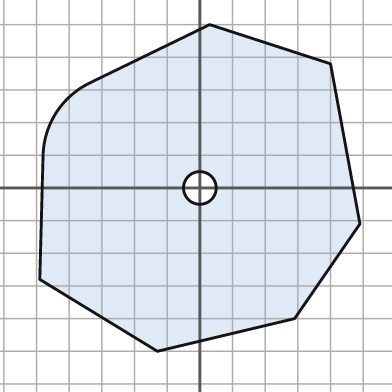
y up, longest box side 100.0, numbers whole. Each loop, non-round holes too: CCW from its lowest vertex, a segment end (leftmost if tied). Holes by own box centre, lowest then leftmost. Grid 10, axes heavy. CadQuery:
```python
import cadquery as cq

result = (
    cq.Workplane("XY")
    .moveTo(-13.0, -50.0)
    .lineTo(29.0, -40.0)
    .lineTo(49.0, -11.0)
    .lineTo(40.0, 38.0)
    .lineTo(3.0, 50.0)
    .lineTo(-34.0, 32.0)
    .threePointArc((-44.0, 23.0), (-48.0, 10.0))
    .lineTo(-49.0, -28.0)
    .close()
    .moveTo(0.0, 0.0)
    .circle(5.0)
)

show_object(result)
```